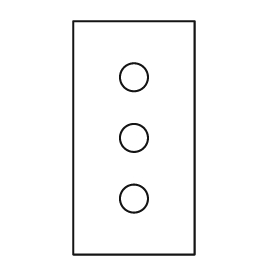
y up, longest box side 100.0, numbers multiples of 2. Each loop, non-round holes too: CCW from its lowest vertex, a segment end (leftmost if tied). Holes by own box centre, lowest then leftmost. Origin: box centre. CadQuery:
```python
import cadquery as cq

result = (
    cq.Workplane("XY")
    .moveTo(-26.0, -50.0)
    .lineTo(26.0, -50.0)
    .lineTo(26.0, 50.0)
    .lineTo(-26.0, 50.0)
    .close()
    .moveTo(0.0, -26.0)
    .circle(6.0)
    .moveTo(0.0, 0.0)
    .circle(6.0)
    .moveTo(0.0, 26.0)
    .circle(6.0)
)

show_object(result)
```